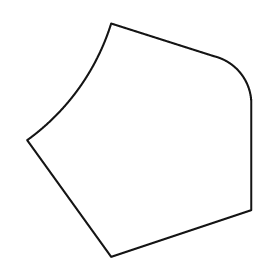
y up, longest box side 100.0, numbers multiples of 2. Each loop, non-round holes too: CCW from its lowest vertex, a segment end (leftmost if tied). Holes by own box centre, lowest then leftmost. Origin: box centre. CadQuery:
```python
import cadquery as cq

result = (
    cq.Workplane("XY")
    .moveTo(-12.0, -50.0)
    .lineTo(48.0, -30.0)
    .lineTo(48.0, 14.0)
    .threePointArc((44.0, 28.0), (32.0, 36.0))
    .lineTo(-12.0, 50.0)
    .threePointArc((-26.0, 22.0), (-48.0, 0.0))
    .close()
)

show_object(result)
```